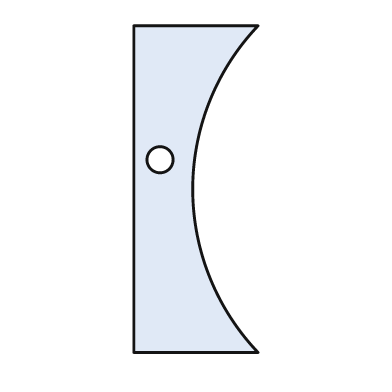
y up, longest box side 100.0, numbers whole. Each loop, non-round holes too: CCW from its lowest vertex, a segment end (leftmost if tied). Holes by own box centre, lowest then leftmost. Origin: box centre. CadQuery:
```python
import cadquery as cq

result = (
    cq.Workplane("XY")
    .moveTo(-19.0, -50.0)
    .lineTo(19.0, -50.0)
    .threePointArc((-1.0, 0.0), (19.0, 50.0))
    .lineTo(-19.0, 50.0)
    .close()
    .moveTo(-11.0, 9.0)
    .circle(4.0)
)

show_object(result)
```